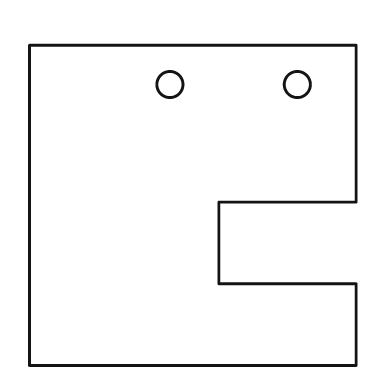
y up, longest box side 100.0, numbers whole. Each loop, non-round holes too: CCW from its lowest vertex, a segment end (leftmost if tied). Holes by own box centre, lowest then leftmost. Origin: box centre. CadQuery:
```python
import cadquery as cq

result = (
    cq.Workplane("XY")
    .moveTo(-50.0, -49.0)
    .lineTo(50.0, -49.0)
    .lineTo(50.0, -24.0)
    .lineTo(8.0, -24.0)
    .lineTo(8.0, 1.0)
    .lineTo(50.0, 1.0)
    .lineTo(50.0, 49.0)
    .lineTo(-50.0, 49.0)
    .close()
    .moveTo(-7.0, 37.0)
    .circle(4.0)
    .moveTo(32.0, 37.0)
    .circle(4.0)
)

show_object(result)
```